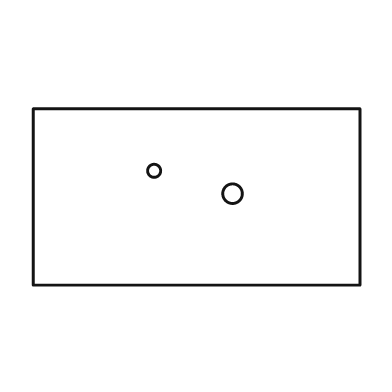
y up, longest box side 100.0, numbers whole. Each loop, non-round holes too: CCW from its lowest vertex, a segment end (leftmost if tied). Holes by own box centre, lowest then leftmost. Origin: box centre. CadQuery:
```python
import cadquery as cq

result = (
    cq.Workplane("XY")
    .moveTo(-50.0, -27.0)
    .lineTo(50.0, -27.0)
    .lineTo(50.0, 27.0)
    .lineTo(-50.0, 27.0)
    .close()
    .moveTo(11.0, 1.0)
    .circle(3.0)
    .moveTo(-13.0, 8.0)
    .circle(2.0)
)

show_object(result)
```